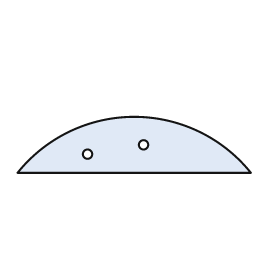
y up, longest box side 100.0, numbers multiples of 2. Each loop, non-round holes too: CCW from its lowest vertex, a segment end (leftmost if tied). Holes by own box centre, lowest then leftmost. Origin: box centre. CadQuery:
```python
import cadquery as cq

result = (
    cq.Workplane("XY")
    .moveTo(-50.0, -12.0)
    .lineTo(50.0, -12.0)
    .threePointArc((0.0, 12.0), (-50.0, -12.0))
    .close()
    .moveTo(-20.0, -4.0)
    .circle(2.0)
    .moveTo(4.0, 0.0)
    .circle(2.0)
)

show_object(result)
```